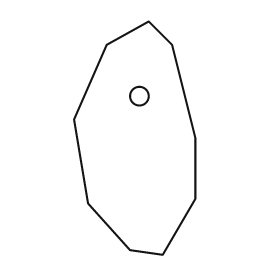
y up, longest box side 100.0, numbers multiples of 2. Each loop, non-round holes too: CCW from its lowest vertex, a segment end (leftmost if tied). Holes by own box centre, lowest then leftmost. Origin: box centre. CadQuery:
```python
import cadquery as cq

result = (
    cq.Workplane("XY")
    .moveTo(12.0, -50.0)
    .lineTo(26.0, -26.0)
    .lineTo(26.0, 0.0)
    .lineTo(16.0, 40.0)
    .lineTo(6.0, 50.0)
    .lineTo(-12.0, 40.0)
    .lineTo(-26.0, 8.0)
    .lineTo(-20.0, -28.0)
    .lineTo(-2.0, -48.0)
    .close()
    .moveTo(2.0, 18.0)
    .circle(4.0)
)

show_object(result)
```